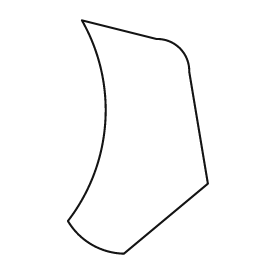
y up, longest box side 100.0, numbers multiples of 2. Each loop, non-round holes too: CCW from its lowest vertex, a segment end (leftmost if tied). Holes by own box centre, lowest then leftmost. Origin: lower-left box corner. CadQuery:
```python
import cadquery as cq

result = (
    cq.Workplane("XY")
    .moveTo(24.0, 0.0)
    .lineTo(60.0, 30.0)
    .lineTo(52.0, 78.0)
    .threePointArc((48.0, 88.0), (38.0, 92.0))
    .lineTo(6.0, 100.0)
    .threePointArc((16.0, 56.0), (0.0, 14.0))
    .threePointArc((10.0, 4.0), (24.0, 0.0))
    .close()
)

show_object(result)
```